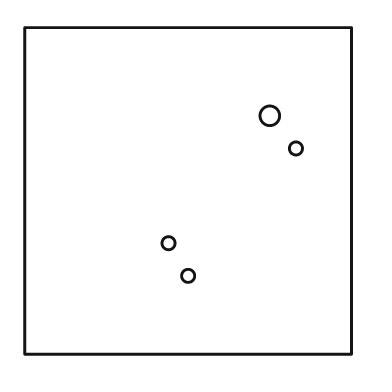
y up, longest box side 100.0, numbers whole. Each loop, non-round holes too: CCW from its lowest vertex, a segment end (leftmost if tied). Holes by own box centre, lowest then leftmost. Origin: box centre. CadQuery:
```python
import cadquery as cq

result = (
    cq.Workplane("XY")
    .moveTo(-50.0, -50.0)
    .lineTo(50.0, -50.0)
    .lineTo(50.0, 50.0)
    .lineTo(-50.0, 50.0)
    .close()
    .moveTo(0.0, -26.0)
    .circle(2.0)
    .moveTo(-6.0, -16.0)
    .circle(2.0)
    .moveTo(33.0, 13.0)
    .circle(2.0)
    .moveTo(25.0, 23.0)
    .circle(3.0)
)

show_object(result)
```